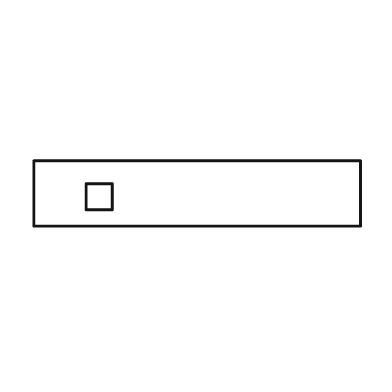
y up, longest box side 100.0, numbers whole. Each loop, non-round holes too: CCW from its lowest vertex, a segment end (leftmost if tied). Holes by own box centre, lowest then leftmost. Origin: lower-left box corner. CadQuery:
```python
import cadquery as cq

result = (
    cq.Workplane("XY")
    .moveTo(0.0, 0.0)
    .lineTo(100.0, 0.0)
    .lineTo(100.0, 20.0)
    .lineTo(0.0, 20.0)
    .close()
    .moveTo(16.0, 5.0)
    .lineTo(24.0, 5.0)
    .lineTo(24.0, 13.0)
    .lineTo(16.0, 13.0)
    .close()
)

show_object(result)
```